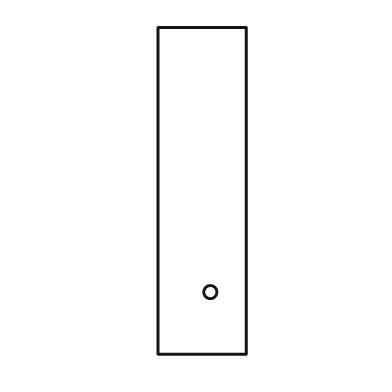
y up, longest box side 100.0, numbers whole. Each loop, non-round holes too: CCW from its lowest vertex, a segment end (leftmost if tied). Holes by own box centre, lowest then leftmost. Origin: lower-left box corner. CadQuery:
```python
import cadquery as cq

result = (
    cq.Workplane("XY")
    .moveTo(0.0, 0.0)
    .lineTo(27.0, 0.0)
    .lineTo(27.0, 100.0)
    .lineTo(0.0, 100.0)
    .close()
    .moveTo(16.0, 19.0)
    .circle(2.0)
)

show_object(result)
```